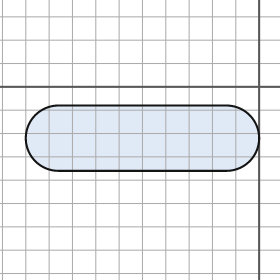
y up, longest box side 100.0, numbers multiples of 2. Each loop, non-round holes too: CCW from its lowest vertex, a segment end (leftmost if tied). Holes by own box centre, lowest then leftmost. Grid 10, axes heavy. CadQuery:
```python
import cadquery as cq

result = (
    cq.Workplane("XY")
    .moveTo(-86.0, -36.0)
    .lineTo(-14.0, -36.0)
    .threePointArc((0.0, -22.0), (-14.0, -8.0))
    .lineTo(-86.0, -8.0)
    .threePointArc((-100.0, -22.0), (-86.0, -36.0))
    .close()
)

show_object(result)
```